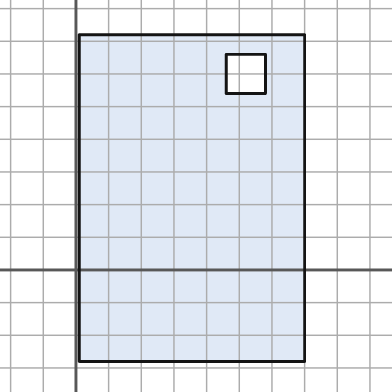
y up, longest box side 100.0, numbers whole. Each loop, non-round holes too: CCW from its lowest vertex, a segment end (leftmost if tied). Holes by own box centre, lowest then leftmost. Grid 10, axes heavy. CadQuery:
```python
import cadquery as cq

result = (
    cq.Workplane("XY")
    .moveTo(1.0, -28.0)
    .lineTo(70.0, -28.0)
    .lineTo(70.0, 72.0)
    .lineTo(1.0, 72.0)
    .close()
    .moveTo(46.0, 54.0)
    .lineTo(58.0, 54.0)
    .lineTo(58.0, 66.0)
    .lineTo(46.0, 66.0)
    .close()
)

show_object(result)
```